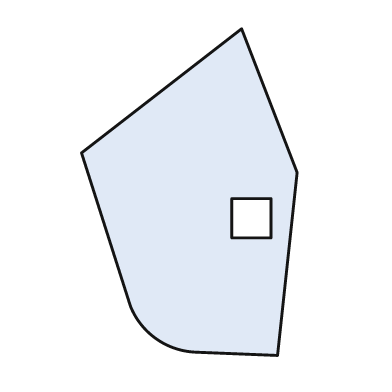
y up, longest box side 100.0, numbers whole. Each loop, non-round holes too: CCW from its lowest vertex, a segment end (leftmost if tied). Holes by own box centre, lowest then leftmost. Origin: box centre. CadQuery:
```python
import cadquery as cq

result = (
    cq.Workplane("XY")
    .moveTo(27.0, -50.0)
    .lineTo(33.0, 6.0)
    .lineTo(16.0, 50.0)
    .lineTo(-33.0, 12.0)
    .lineTo(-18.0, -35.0)
    .threePointArc((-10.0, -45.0), (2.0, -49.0))
    .close()
    .moveTo(13.0, -14.0)
    .lineTo(25.0, -14.0)
    .lineTo(25.0, -2.0)
    .lineTo(13.0, -2.0)
    .close()
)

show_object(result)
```